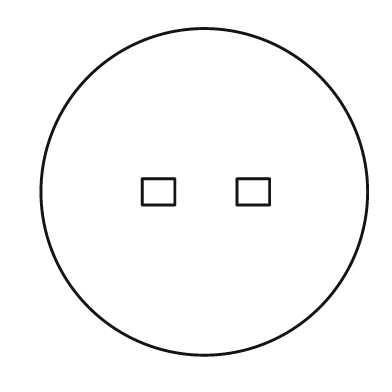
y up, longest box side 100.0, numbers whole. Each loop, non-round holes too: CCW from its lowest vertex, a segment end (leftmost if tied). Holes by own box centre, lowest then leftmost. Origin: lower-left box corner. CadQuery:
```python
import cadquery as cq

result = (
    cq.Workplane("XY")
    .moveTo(50.0, 50.0)
    .circle(50.0)
    .moveTo(31.0, 46.0)
    .lineTo(41.0, 46.0)
    .lineTo(41.0, 54.0)
    .lineTo(31.0, 54.0)
    .close()
    .moveTo(60.0, 46.0)
    .lineTo(70.0, 46.0)
    .lineTo(70.0, 54.0)
    .lineTo(60.0, 54.0)
    .close()
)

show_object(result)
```